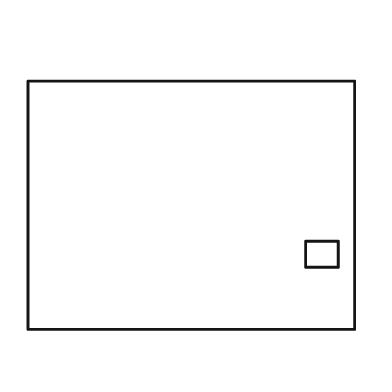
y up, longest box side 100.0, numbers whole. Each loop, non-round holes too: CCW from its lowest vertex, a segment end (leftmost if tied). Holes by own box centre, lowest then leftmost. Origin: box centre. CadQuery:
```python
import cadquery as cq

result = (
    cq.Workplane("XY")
    .moveTo(-50.0, -38.0)
    .lineTo(50.0, -38.0)
    .lineTo(50.0, 38.0)
    .lineTo(-50.0, 38.0)
    .close()
    .moveTo(35.0, -19.0)
    .lineTo(45.0, -19.0)
    .lineTo(45.0, -11.0)
    .lineTo(35.0, -11.0)
    .close()
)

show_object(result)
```